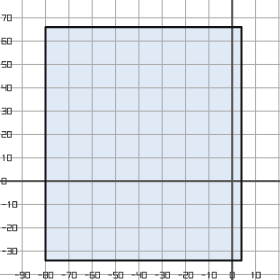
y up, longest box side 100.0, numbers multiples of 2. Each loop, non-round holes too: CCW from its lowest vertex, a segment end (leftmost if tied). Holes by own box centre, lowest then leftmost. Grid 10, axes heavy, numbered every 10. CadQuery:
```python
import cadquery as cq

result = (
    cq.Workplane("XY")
    .moveTo(-80.0, -34.0)
    .lineTo(4.0, -34.0)
    .lineTo(4.0, 66.0)
    .lineTo(-80.0, 66.0)
    .close()
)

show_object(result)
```